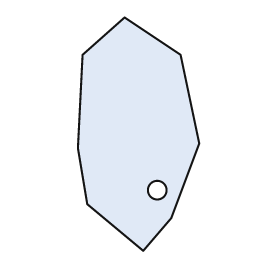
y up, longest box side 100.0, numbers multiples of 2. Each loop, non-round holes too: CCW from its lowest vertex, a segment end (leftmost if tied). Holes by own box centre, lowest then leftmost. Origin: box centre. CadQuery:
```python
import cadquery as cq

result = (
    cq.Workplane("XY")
    .moveTo(2.0, -50.0)
    .lineTo(14.0, -36.0)
    .lineTo(26.0, -4.0)
    .lineTo(18.0, 34.0)
    .lineTo(-6.0, 50.0)
    .lineTo(-24.0, 34.0)
    .lineTo(-26.0, -6.0)
    .lineTo(-22.0, -30.0)
    .close()
    .moveTo(8.0, -24.0)
    .circle(4.0)
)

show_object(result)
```